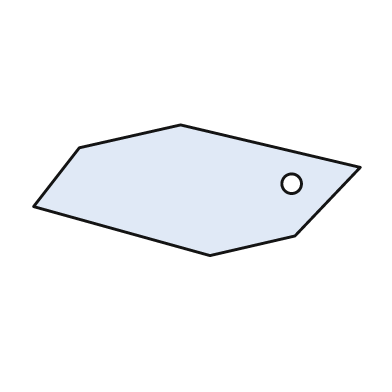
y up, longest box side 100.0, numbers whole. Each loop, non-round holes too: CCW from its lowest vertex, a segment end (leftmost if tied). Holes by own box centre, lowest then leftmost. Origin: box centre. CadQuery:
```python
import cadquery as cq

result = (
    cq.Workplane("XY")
    .moveTo(4.0, -20.0)
    .lineTo(30.0, -14.0)
    .lineTo(50.0, 7.0)
    .lineTo(-5.0, 20.0)
    .lineTo(-36.0, 13.0)
    .lineTo(-50.0, -5.0)
    .close()
    .moveTo(29.0, 2.0)
    .circle(3.0)
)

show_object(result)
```